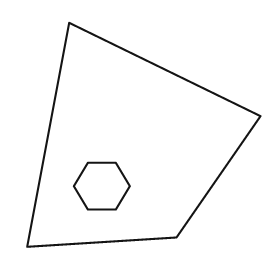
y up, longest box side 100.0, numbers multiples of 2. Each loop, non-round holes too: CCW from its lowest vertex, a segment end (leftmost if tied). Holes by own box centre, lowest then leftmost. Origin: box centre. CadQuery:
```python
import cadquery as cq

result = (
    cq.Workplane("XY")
    .moveTo(-50.0, -48.0)
    .lineTo(14.0, -44.0)
    .lineTo(50.0, 8.0)
    .lineTo(-32.0, 48.0)
    .close()
    .moveTo(-24.0, -32.0)
    .lineTo(-12.0, -32.0)
    .lineTo(-6.0, -22.0)
    .lineTo(-12.0, -12.0)
    .lineTo(-24.0, -12.0)
    .lineTo(-30.0, -22.0)
    .close()
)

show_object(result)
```